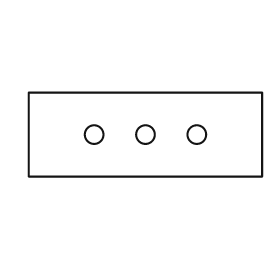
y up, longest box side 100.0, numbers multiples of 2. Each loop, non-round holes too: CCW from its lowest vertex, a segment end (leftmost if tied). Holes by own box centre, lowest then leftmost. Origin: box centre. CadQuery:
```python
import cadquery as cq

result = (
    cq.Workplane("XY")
    .moveTo(-50.0, -18.0)
    .lineTo(50.0, -18.0)
    .lineTo(50.0, 18.0)
    .lineTo(-50.0, 18.0)
    .close()
    .moveTo(-22.0, 0.0)
    .circle(4.0)
    .moveTo(0.0, 0.0)
    .circle(4.0)
    .moveTo(22.0, 0.0)
    .circle(4.0)
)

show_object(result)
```